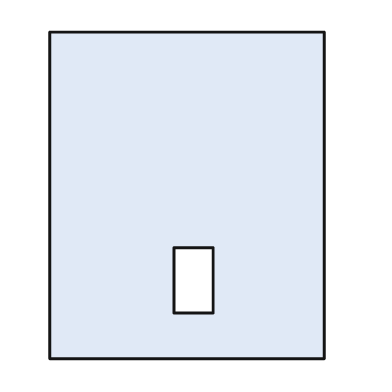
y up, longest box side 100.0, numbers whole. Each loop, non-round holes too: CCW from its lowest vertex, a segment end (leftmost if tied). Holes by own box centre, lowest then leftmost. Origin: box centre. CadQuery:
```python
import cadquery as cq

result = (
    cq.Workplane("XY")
    .moveTo(-42.0, -50.0)
    .lineTo(42.0, -50.0)
    .lineTo(42.0, 50.0)
    .lineTo(-42.0, 50.0)
    .close()
    .moveTo(-4.0, -36.0)
    .lineTo(8.0, -36.0)
    .lineTo(8.0, -16.0)
    .lineTo(-4.0, -16.0)
    .close()
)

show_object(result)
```